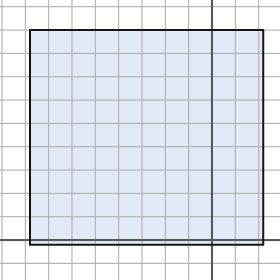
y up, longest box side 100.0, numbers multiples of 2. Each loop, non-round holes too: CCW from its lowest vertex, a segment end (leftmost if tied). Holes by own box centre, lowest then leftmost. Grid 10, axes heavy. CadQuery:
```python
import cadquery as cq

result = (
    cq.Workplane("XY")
    .moveTo(-78.0, -2.0)
    .lineTo(22.0, -2.0)
    .lineTo(22.0, 90.0)
    .lineTo(-78.0, 90.0)
    .close()
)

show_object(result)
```